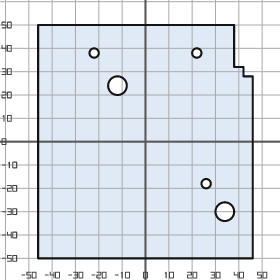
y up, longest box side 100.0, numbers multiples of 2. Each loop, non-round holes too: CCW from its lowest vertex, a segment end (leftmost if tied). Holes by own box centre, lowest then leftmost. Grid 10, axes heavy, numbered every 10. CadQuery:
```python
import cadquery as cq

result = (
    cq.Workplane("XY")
    .moveTo(-46.0, -50.0)
    .lineTo(46.0, -50.0)
    .lineTo(46.0, 28.0)
    .lineTo(42.0, 28.0)
    .lineTo(42.0, 32.0)
    .lineTo(38.0, 32.0)
    .lineTo(38.0, 50.0)
    .lineTo(-46.0, 50.0)
    .close()
    .moveTo(34.0, -30.0)
    .circle(4.0)
    .moveTo(26.0, -18.0)
    .circle(2.0)
    .moveTo(-12.0, 24.0)
    .circle(4.0)
    .moveTo(-22.0, 38.0)
    .circle(2.0)
    .moveTo(22.0, 38.0)
    .circle(2.0)
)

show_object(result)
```